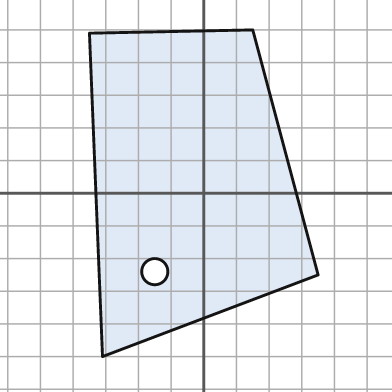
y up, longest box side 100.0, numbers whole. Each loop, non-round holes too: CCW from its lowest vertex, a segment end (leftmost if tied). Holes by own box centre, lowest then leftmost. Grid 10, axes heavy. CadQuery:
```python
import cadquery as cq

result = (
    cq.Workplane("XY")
    .moveTo(-31.0, -50.0)
    .lineTo(35.0, -25.0)
    .lineTo(15.0, 50.0)
    .lineTo(-35.0, 49.0)
    .close()
    .moveTo(-15.0, -24.0)
    .circle(4.0)
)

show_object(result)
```